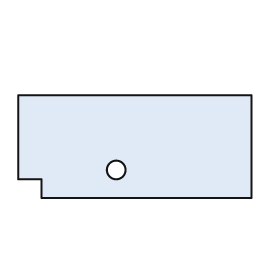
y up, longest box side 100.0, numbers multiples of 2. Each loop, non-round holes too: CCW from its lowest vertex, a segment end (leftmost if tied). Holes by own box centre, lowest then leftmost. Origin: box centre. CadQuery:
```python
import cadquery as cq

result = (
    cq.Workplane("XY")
    .moveTo(-40.0, -22.0)
    .lineTo(50.0, -22.0)
    .lineTo(50.0, 22.0)
    .lineTo(-50.0, 22.0)
    .lineTo(-50.0, -14.0)
    .lineTo(-40.0, -14.0)
    .close()
    .moveTo(-8.0, -10.0)
    .circle(4.0)
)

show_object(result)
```